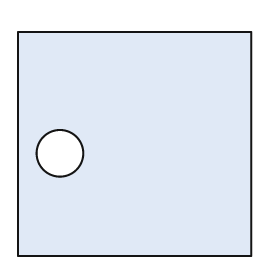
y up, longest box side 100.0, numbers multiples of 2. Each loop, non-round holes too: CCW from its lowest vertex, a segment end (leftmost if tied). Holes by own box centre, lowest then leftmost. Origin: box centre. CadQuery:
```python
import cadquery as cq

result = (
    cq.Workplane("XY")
    .moveTo(-50.0, -48.0)
    .lineTo(50.0, -48.0)
    .lineTo(50.0, 48.0)
    .lineTo(-50.0, 48.0)
    .close()
    .moveTo(-32.0, -4.0)
    .circle(10.0)
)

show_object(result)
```